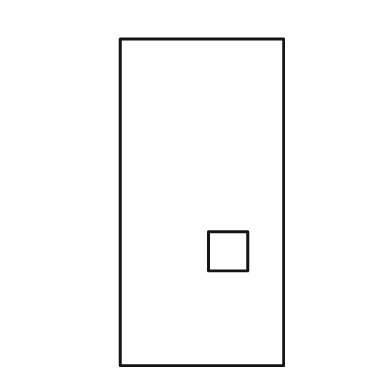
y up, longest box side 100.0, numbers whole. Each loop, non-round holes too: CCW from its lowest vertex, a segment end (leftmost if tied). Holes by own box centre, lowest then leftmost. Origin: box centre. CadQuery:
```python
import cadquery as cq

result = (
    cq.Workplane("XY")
    .moveTo(-25.0, -50.0)
    .lineTo(25.0, -50.0)
    .lineTo(25.0, 50.0)
    .lineTo(-25.0, 50.0)
    .close()
    .moveTo(2.0, -21.0)
    .lineTo(14.0, -21.0)
    .lineTo(14.0, -9.0)
    .lineTo(2.0, -9.0)
    .close()
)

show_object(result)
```